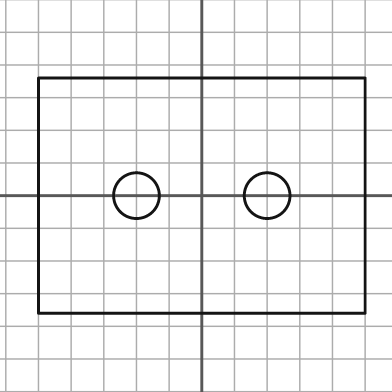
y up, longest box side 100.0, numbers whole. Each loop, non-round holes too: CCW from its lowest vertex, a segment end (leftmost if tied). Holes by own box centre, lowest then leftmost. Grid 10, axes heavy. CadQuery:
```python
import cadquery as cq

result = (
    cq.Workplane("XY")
    .moveTo(-50.0, -36.0)
    .lineTo(50.0, -36.0)
    .lineTo(50.0, 36.0)
    .lineTo(-50.0, 36.0)
    .close()
    .moveTo(-20.0, 0.0)
    .circle(7.0)
    .moveTo(20.0, 0.0)
    .circle(7.0)
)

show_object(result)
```